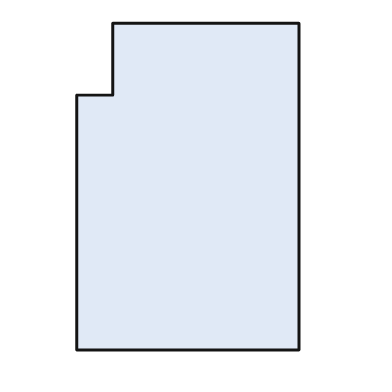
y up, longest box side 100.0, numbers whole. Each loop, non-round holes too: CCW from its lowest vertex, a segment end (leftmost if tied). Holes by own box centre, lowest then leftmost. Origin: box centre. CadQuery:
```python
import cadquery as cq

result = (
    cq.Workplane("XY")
    .moveTo(-34.0, -50.0)
    .lineTo(34.0, -50.0)
    .lineTo(34.0, 50.0)
    .lineTo(-23.0, 50.0)
    .lineTo(-23.0, 28.0)
    .lineTo(-34.0, 28.0)
    .close()
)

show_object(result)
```